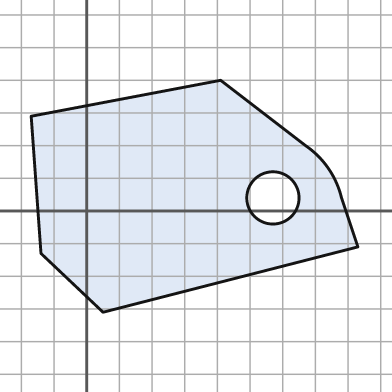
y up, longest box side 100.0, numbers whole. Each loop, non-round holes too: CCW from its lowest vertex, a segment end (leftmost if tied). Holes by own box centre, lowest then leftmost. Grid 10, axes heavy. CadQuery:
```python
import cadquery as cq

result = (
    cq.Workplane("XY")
    .moveTo(5.0, -31.0)
    .lineTo(83.0, -11.0)
    .lineTo(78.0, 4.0)
    .threePointArc((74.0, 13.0), (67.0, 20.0))
    .lineTo(41.0, 40.0)
    .lineTo(-17.0, 29.0)
    .lineTo(-14.0, -13.0)
    .close()
    .moveTo(57.0, 4.0)
    .circle(8.0)
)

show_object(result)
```